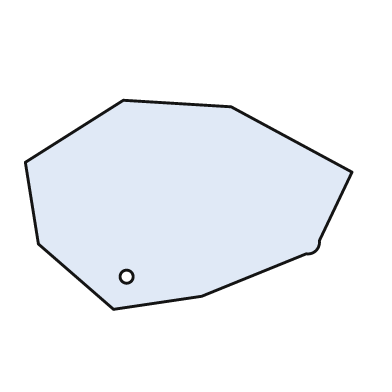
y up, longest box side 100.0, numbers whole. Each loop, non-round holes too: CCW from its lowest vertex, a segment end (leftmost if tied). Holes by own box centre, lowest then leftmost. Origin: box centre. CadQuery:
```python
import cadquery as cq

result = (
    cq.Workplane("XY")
    .moveTo(-23.0, -32.0)
    .lineTo(4.0, -28.0)
    .lineTo(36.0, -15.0)
    .threePointArc((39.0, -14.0), (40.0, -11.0))
    .lineTo(50.0, 10.0)
    .lineTo(13.0, 30.0)
    .lineTo(-20.0, 32.0)
    .lineTo(-50.0, 13.0)
    .lineTo(-46.0, -12.0)
    .close()
    .moveTo(-19.0, -22.0)
    .circle(2.0)
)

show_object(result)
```